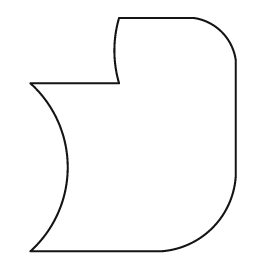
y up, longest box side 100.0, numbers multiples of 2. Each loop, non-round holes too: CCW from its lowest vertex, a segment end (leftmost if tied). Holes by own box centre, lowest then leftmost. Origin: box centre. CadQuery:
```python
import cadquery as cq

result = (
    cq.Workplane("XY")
    .moveTo(-44.0, -50.0)
    .lineTo(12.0, -50.0)
    .threePointArc((34.0, -40.0), (44.0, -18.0))
    .lineTo(44.0, 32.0)
    .threePointArc((38.0, 44.0), (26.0, 50.0))
    .lineTo(-6.0, 50.0)
    .threePointArc((-8.0, 36.0), (-6.0, 22.0))
    .lineTo(-44.0, 22.0)
    .threePointArc((-28.0, -14.0), (-44.0, -50.0))
    .close()
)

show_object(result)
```